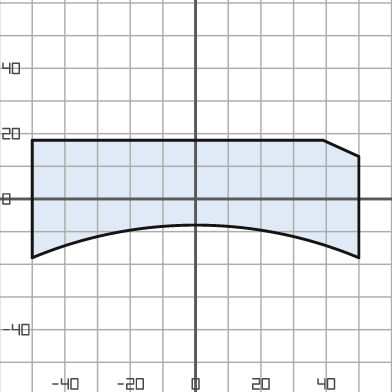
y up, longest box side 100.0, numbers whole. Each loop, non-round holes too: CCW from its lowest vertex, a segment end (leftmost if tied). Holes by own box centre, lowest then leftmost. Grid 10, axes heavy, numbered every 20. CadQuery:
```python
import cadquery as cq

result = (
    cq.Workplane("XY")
    .moveTo(-50.0, -18.0)
    .threePointArc((0.0, -8.0), (50.0, -18.0))
    .lineTo(50.0, 13.0)
    .lineTo(39.0, 18.0)
    .lineTo(-50.0, 18.0)
    .close()
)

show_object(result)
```